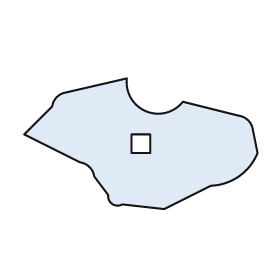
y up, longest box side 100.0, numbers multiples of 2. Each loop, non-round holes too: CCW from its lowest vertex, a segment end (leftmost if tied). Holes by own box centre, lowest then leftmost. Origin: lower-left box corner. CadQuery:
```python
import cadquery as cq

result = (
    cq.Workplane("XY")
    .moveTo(60.0, 0.0)
    .lineTo(80.0, 10.0)
    .threePointArc((92.0, 14.0), (100.0, 24.0))
    .lineTo(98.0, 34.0)
    .threePointArc((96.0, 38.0), (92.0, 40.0))
    .lineTo(68.0, 46.0)
    .threePointArc((52.0, 42.0), (44.0, 56.0))
    .lineTo(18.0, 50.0)
    .threePointArc((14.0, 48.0), (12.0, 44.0))
    .lineTo(0.0, 32.0)
    .lineTo(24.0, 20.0)
    .threePointArc((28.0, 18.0), (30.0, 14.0))
    .lineTo(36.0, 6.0)
    .threePointArc((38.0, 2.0), (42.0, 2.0))
    .close()
    .moveTo(46.0, 24.0)
    .lineTo(54.0, 24.0)
    .lineTo(54.0, 32.0)
    .lineTo(46.0, 32.0)
    .close()
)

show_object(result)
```